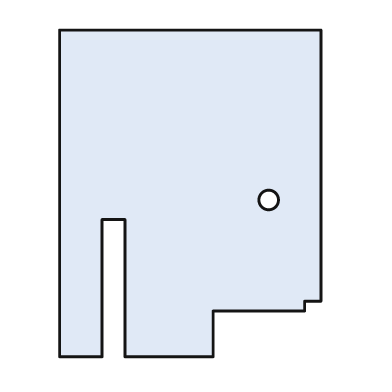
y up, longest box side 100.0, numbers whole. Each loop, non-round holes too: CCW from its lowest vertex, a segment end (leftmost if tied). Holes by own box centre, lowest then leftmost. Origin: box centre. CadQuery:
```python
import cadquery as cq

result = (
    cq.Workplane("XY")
    .moveTo(-40.0, -50.0)
    .lineTo(-27.0, -50.0)
    .lineTo(-27.0, -8.0)
    .lineTo(-20.0, -8.0)
    .lineTo(-20.0, -50.0)
    .lineTo(7.0, -50.0)
    .lineTo(7.0, -36.0)
    .lineTo(35.0, -36.0)
    .lineTo(35.0, -33.0)
    .lineTo(40.0, -33.0)
    .lineTo(40.0, 50.0)
    .lineTo(-40.0, 50.0)
    .close()
    .moveTo(24.0, -2.0)
    .circle(3.0)
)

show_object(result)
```